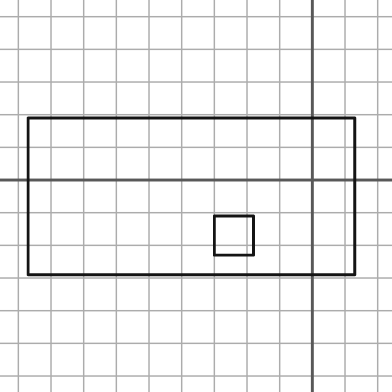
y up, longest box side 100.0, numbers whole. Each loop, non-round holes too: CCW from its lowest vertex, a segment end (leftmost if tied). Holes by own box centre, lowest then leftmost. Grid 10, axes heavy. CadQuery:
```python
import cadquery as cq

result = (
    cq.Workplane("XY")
    .moveTo(-87.0, -29.0)
    .lineTo(13.0, -29.0)
    .lineTo(13.0, 19.0)
    .lineTo(-87.0, 19.0)
    .close()
    .moveTo(-30.0, -23.0)
    .lineTo(-18.0, -23.0)
    .lineTo(-18.0, -11.0)
    .lineTo(-30.0, -11.0)
    .close()
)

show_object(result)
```